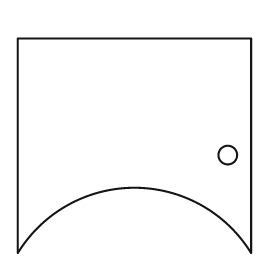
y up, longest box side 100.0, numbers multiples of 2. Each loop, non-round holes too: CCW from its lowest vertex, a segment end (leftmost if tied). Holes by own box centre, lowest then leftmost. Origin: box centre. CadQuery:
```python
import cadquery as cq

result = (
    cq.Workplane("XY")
    .moveTo(-50.0, -46.0)
    .threePointArc((0.0, -18.0), (50.0, -46.0))
    .lineTo(50.0, 46.0)
    .lineTo(-50.0, 46.0)
    .close()
    .moveTo(40.0, -4.0)
    .circle(4.0)
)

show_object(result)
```